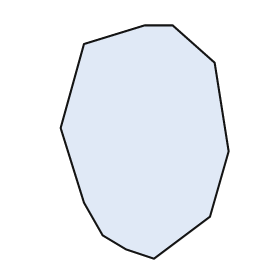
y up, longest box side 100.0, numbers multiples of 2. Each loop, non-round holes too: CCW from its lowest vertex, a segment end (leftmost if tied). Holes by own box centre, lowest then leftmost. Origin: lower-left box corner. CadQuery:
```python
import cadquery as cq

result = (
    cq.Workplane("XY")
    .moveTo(40.0, 0.0)
    .lineTo(64.0, 18.0)
    .lineTo(72.0, 46.0)
    .lineTo(66.0, 84.0)
    .lineTo(48.0, 100.0)
    .lineTo(36.0, 100.0)
    .lineTo(10.0, 92.0)
    .lineTo(0.0, 56.0)
    .lineTo(10.0, 24.0)
    .lineTo(18.0, 10.0)
    .lineTo(28.0, 4.0)
    .close()
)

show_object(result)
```